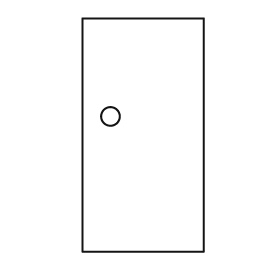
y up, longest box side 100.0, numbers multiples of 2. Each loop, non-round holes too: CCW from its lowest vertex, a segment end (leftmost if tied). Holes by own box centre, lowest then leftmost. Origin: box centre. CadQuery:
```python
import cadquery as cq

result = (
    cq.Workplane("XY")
    .moveTo(-26.0, -50.0)
    .lineTo(26.0, -50.0)
    .lineTo(26.0, 50.0)
    .lineTo(-26.0, 50.0)
    .close()
    .moveTo(-14.0, 8.0)
    .circle(4.0)
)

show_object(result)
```